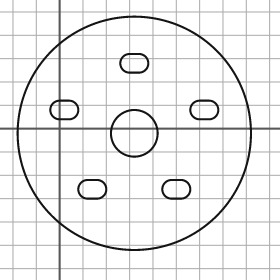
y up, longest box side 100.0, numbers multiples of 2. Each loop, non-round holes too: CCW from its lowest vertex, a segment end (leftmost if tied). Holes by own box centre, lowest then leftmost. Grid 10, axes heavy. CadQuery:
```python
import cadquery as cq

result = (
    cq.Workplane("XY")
    .moveTo(32.0, -2.0)
    .circle(50.0)
    .moveTo(12.0, -30.0)
    .lineTo(16.0, -30.0)
    .threePointArc((20.0, -26.0), (16.0, -22.0))
    .lineTo(12.0, -22.0)
    .threePointArc((8.0, -26.0), (12.0, -30.0))
    .close()
    .moveTo(48.0, -30.0)
    .lineTo(52.0, -30.0)
    .threePointArc((56.0, -26.0), (52.0, -22.0))
    .lineTo(48.0, -22.0)
    .threePointArc((44.0, -26.0), (48.0, -30.0))
    .close()
    .moveTo(32.0, -2.0)
    .circle(10.0)
    .moveTo(0.0, 4.0)
    .lineTo(4.0, 4.0)
    .threePointArc((8.0, 8.0), (4.0, 12.0))
    .lineTo(0.0, 12.0)
    .threePointArc((-4.0, 8.0), (0.0, 4.0))
    .close()
    .moveTo(60.0, 4.0)
    .lineTo(64.0, 4.0)
    .threePointArc((68.0, 8.0), (64.0, 12.0))
    .lineTo(60.0, 12.0)
    .threePointArc((56.0, 8.0), (60.0, 4.0))
    .close()
    .moveTo(30.0, 24.0)
    .lineTo(34.0, 24.0)
    .threePointArc((38.0, 28.0), (34.0, 32.0))
    .lineTo(30.0, 32.0)
    .threePointArc((26.0, 28.0), (30.0, 24.0))
    .close()
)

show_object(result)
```